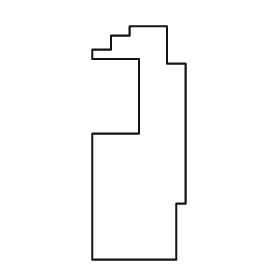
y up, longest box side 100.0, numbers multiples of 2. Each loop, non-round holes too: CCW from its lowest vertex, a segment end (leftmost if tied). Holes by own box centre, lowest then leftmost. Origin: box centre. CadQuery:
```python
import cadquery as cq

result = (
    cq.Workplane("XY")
    .moveTo(-20.0, -50.0)
    .lineTo(16.0, -50.0)
    .lineTo(16.0, -26.0)
    .lineTo(20.0, -26.0)
    .lineTo(20.0, 34.0)
    .lineTo(12.0, 34.0)
    .lineTo(12.0, 50.0)
    .lineTo(-4.0, 50.0)
    .lineTo(-4.0, 46.0)
    .lineTo(-12.0, 46.0)
    .lineTo(-12.0, 40.0)
    .lineTo(-20.0, 40.0)
    .lineTo(-20.0, 36.0)
    .lineTo(0.0, 36.0)
    .lineTo(0.0, 4.0)
    .lineTo(-20.0, 4.0)
    .close()
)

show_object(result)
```